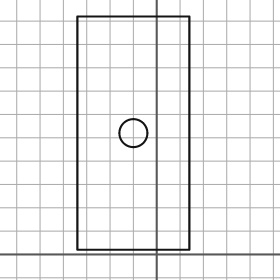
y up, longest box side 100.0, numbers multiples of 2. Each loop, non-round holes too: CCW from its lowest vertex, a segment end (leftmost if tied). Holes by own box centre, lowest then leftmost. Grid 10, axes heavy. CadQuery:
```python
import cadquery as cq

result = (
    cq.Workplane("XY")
    .moveTo(-34.0, 2.0)
    .lineTo(14.0, 2.0)
    .lineTo(14.0, 102.0)
    .lineTo(-34.0, 102.0)
    .close()
    .moveTo(-10.0, 52.0)
    .circle(6.0)
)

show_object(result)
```